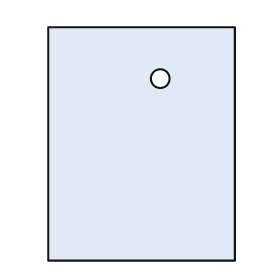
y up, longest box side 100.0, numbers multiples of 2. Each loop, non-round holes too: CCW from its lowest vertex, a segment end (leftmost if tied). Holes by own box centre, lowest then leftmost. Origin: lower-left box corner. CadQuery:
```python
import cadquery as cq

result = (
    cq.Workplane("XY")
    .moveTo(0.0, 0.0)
    .lineTo(80.0, 0.0)
    .lineTo(80.0, 100.0)
    .lineTo(0.0, 100.0)
    .close()
    .moveTo(48.0, 78.0)
    .circle(4.0)
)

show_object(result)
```